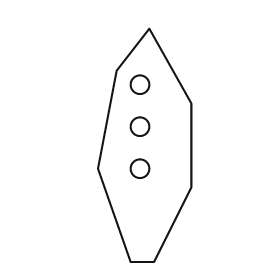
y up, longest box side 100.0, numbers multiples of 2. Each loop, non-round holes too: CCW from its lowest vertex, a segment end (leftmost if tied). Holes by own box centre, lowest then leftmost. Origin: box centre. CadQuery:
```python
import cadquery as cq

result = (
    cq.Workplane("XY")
    .moveTo(-6.0, -50.0)
    .lineTo(4.0, -50.0)
    .lineTo(20.0, -18.0)
    .lineTo(20.0, 18.0)
    .lineTo(2.0, 50.0)
    .lineTo(-12.0, 32.0)
    .lineTo(-20.0, -10.0)
    .close()
    .moveTo(-2.0, -10.0)
    .circle(4.0)
    .moveTo(-2.0, 8.0)
    .circle(4.0)
    .moveTo(-2.0, 26.0)
    .circle(4.0)
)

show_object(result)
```